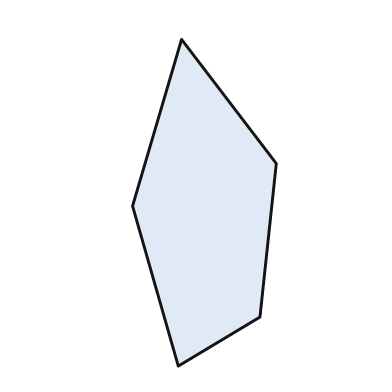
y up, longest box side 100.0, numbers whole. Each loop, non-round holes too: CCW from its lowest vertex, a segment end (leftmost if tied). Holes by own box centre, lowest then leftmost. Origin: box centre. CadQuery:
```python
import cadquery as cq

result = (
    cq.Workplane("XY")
    .moveTo(-8.0, -50.0)
    .lineTo(17.0, -35.0)
    .lineTo(22.0, 12.0)
    .lineTo(-7.0, 50.0)
    .lineTo(-22.0, -1.0)
    .close()
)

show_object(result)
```